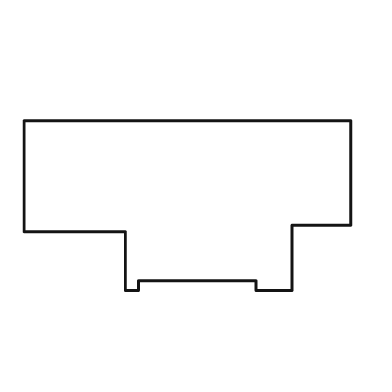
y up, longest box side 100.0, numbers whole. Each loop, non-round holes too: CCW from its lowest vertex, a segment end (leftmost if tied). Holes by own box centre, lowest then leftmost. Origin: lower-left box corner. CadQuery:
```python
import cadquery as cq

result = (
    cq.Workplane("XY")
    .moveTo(31.0, 0.0)
    .lineTo(35.0, 0.0)
    .lineTo(35.0, 3.0)
    .lineTo(71.0, 3.0)
    .lineTo(71.0, 0.0)
    .lineTo(82.0, 0.0)
    .lineTo(82.0, 20.0)
    .lineTo(100.0, 20.0)
    .lineTo(100.0, 52.0)
    .lineTo(0.0, 52.0)
    .lineTo(0.0, 18.0)
    .lineTo(31.0, 18.0)
    .close()
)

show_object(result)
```